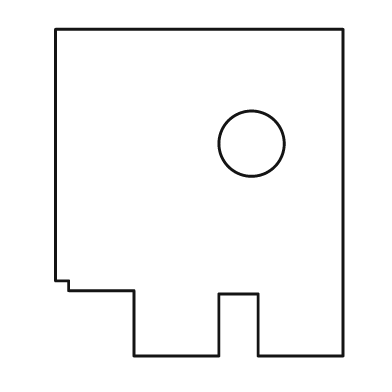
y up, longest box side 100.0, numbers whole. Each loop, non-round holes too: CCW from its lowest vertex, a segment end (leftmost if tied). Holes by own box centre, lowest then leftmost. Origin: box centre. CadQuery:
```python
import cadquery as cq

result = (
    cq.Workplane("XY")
    .moveTo(-20.0, -50.0)
    .lineTo(6.0, -50.0)
    .lineTo(6.0, -31.0)
    .lineTo(18.0, -31.0)
    .lineTo(18.0, -50.0)
    .lineTo(44.0, -50.0)
    .lineTo(44.0, 50.0)
    .lineTo(-44.0, 50.0)
    .lineTo(-44.0, -27.0)
    .lineTo(-40.0, -27.0)
    .lineTo(-40.0, -30.0)
    .lineTo(-20.0, -30.0)
    .close()
    .moveTo(16.0, 15.0)
    .circle(10.0)
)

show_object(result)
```